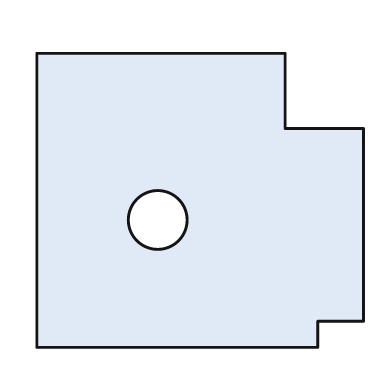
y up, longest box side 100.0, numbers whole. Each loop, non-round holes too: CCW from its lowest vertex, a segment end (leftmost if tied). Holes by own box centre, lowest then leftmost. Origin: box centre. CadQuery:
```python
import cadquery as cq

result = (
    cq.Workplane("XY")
    .moveTo(-50.0, -45.0)
    .lineTo(36.0, -45.0)
    .lineTo(36.0, -37.0)
    .lineTo(50.0, -37.0)
    .lineTo(50.0, 22.0)
    .lineTo(26.0, 22.0)
    .lineTo(26.0, 45.0)
    .lineTo(-50.0, 45.0)
    .close()
    .moveTo(-13.0, -6.0)
    .circle(9.0)
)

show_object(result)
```